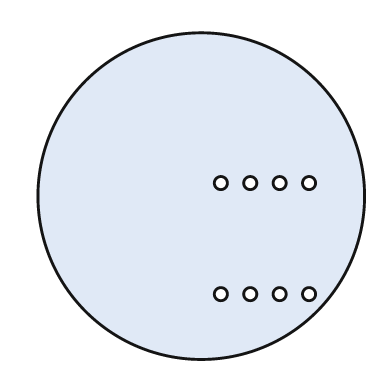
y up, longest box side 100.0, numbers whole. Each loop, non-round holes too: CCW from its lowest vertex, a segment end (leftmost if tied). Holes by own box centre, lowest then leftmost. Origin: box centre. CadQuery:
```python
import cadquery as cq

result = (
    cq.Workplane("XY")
    .moveTo(0.0, 0.0)
    .circle(50.0)
    .moveTo(6.0, -30.0)
    .circle(2.0)
    .moveTo(15.0, -30.0)
    .circle(2.0)
    .moveTo(24.0, -30.0)
    .circle(2.0)
    .moveTo(33.0, -30.0)
    .circle(2.0)
    .moveTo(6.0, 4.0)
    .circle(2.0)
    .moveTo(15.0, 4.0)
    .circle(2.0)
    .moveTo(24.0, 4.0)
    .circle(2.0)
    .moveTo(33.0, 4.0)
    .circle(2.0)
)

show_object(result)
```